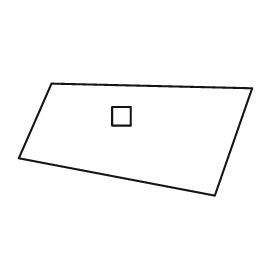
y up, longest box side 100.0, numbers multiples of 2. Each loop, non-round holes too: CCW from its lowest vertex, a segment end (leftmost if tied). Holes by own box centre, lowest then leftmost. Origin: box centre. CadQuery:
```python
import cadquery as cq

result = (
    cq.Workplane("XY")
    .moveTo(34.0, -24.0)
    .lineTo(50.0, 22.0)
    .lineTo(-36.0, 24.0)
    .lineTo(-50.0, -8.0)
    .close()
    .moveTo(-10.0, 6.0)
    .lineTo(-2.0, 6.0)
    .lineTo(-2.0, 14.0)
    .lineTo(-10.0, 14.0)
    .close()
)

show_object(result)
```